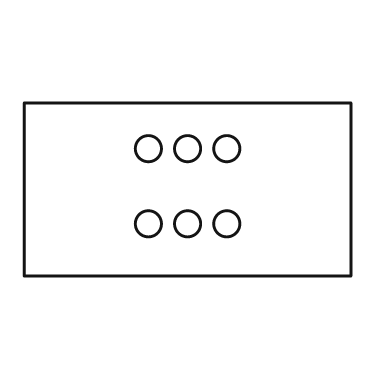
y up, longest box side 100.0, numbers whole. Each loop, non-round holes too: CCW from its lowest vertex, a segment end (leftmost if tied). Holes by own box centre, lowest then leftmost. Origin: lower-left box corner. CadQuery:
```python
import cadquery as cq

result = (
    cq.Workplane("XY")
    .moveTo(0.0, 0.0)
    .lineTo(100.0, 0.0)
    .lineTo(100.0, 53.0)
    .lineTo(0.0, 53.0)
    .close()
    .moveTo(38.0, 16.0)
    .circle(4.0)
    .moveTo(50.0, 16.0)
    .circle(4.0)
    .moveTo(62.0, 16.0)
    .circle(4.0)
    .moveTo(38.0, 39.0)
    .circle(4.0)
    .moveTo(50.0, 39.0)
    .circle(4.0)
    .moveTo(62.0, 39.0)
    .circle(4.0)
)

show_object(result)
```